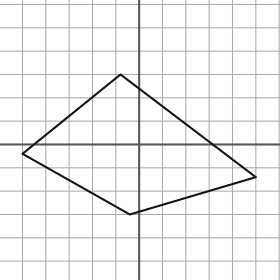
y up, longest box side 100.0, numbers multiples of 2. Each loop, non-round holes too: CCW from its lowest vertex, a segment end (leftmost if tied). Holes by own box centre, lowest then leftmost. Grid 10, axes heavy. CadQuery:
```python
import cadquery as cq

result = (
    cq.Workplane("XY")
    .moveTo(-4.0, -30.0)
    .lineTo(50.0, -14.0)
    .lineTo(-8.0, 30.0)
    .lineTo(-50.0, -4.0)
    .close()
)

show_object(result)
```